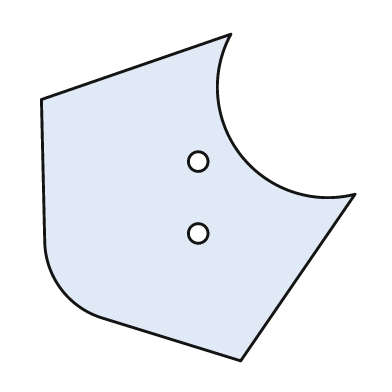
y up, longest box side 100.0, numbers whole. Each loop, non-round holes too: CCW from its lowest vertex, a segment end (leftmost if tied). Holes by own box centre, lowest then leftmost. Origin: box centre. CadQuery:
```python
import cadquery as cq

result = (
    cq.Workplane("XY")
    .moveTo(13.0, -50.0)
    .lineTo(48.0, 1.0)
    .threePointArc((13.0, 13.0), (10.0, 50.0))
    .lineTo(-48.0, 30.0)
    .lineTo(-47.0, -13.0)
    .threePointArc((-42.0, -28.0), (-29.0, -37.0))
    .close()
    .moveTo(0.0, -11.0)
    .circle(3.0)
    .moveTo(0.0, 11.0)
    .circle(3.0)
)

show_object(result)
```